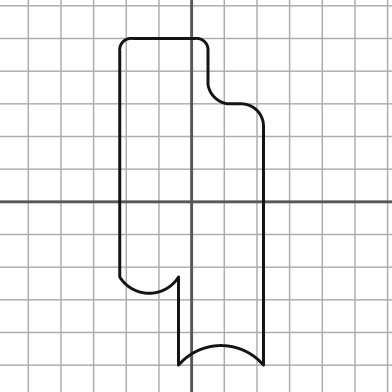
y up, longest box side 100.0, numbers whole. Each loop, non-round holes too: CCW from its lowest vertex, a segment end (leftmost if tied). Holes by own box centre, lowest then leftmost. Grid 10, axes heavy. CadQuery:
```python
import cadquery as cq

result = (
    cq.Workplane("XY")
    .moveTo(-4.0, -50.0)
    .threePointArc((9.0, -44.0), (22.0, -50.0))
    .lineTo(22.0, 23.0)
    .threePointArc((20.0, 28.0), (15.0, 30.0))
    .lineTo(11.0, 30.0)
    .threePointArc((7.0, 32.0), (5.0, 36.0))
    .lineTo(5.0, 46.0)
    .threePointArc((4.0, 49.0), (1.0, 50.0))
    .lineTo(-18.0, 50.0)
    .threePointArc((-21.0, 49.0), (-22.0, 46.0))
    .lineTo(-22.0, -23.0)
    .threePointArc((-13.0, -28.0), (-4.0, -23.0))
    .close()
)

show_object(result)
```